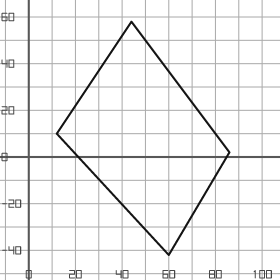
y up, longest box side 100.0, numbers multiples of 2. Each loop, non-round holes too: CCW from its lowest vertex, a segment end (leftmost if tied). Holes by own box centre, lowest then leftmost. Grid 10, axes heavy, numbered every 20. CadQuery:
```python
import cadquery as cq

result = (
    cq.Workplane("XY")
    .moveTo(60.0, -42.0)
    .lineTo(86.0, 2.0)
    .lineTo(44.0, 58.0)
    .lineTo(12.0, 10.0)
    .close()
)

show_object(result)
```